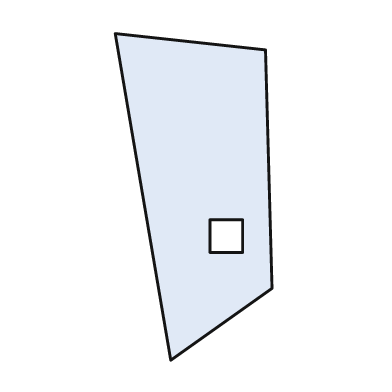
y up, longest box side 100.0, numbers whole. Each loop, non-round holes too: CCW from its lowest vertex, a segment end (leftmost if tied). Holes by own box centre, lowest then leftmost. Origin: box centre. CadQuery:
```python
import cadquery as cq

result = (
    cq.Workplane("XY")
    .moveTo(-7.0, -50.0)
    .lineTo(24.0, -28.0)
    .lineTo(22.0, 45.0)
    .lineTo(-24.0, 50.0)
    .close()
    .moveTo(5.0, -17.0)
    .lineTo(15.0, -17.0)
    .lineTo(15.0, -7.0)
    .lineTo(5.0, -7.0)
    .close()
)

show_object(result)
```